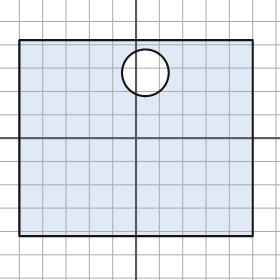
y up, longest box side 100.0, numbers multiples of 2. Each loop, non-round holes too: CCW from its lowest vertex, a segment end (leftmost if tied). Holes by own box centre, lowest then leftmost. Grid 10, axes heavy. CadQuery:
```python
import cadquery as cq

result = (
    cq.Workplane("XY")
    .moveTo(-50.0, -42.0)
    .lineTo(50.0, -42.0)
    .lineTo(50.0, 42.0)
    .lineTo(-50.0, 42.0)
    .close()
    .moveTo(4.0, 28.0)
    .circle(10.0)
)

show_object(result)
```